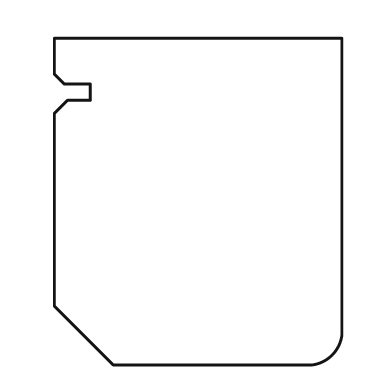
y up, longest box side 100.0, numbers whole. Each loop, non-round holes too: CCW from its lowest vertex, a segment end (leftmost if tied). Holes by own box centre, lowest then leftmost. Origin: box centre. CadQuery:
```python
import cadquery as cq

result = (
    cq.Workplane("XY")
    .moveTo(-26.0, -50.0)
    .lineTo(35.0, -50.0)
    .threePointArc((41.0, -47.0), (44.0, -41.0))
    .lineTo(44.0, 50.0)
    .lineTo(-44.0, 50.0)
    .lineTo(-44.0, 39.0)
    .lineTo(-41.0, 36.0)
    .lineTo(-33.0, 36.0)
    .lineTo(-33.0, 31.0)
    .lineTo(-40.0, 31.0)
    .lineTo(-44.0, 27.0)
    .lineTo(-44.0, -32.0)
    .close()
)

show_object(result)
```